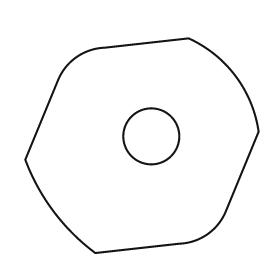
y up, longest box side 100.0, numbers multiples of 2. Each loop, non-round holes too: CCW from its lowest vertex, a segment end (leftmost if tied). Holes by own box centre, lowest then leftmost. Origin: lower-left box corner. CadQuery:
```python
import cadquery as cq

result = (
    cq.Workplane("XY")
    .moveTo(30.0, 0.0)
    .lineTo(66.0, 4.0)
    .threePointArc((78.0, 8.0), (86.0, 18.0))
    .lineTo(100.0, 52.0)
    .threePointArc((90.0, 76.0), (70.0, 92.0))
    .lineTo(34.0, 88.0)
    .threePointArc((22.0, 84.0), (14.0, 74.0))
    .lineTo(0.0, 40.0)
    .threePointArc((12.0, 18.0), (30.0, 0.0))
    .close()
    .moveTo(54.0, 50.0)
    .circle(12.0)
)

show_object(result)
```